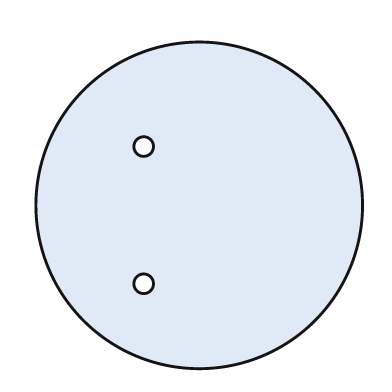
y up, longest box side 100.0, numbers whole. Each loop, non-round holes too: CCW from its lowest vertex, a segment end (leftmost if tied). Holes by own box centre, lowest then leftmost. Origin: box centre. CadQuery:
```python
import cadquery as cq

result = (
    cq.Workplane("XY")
    .moveTo(0.0, 0.0)
    .circle(50.0)
    .moveTo(-17.0, -24.0)
    .circle(3.0)
    .moveTo(-17.0, 18.0)
    .circle(3.0)
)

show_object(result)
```